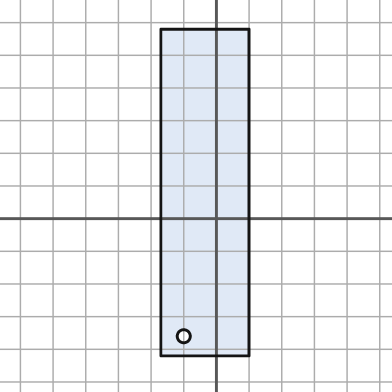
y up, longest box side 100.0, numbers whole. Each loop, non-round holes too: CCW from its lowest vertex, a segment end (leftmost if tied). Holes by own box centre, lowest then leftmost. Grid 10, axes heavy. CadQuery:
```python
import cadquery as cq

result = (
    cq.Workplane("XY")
    .moveTo(-17.0, -42.0)
    .lineTo(10.0, -42.0)
    .lineTo(10.0, 58.0)
    .lineTo(-17.0, 58.0)
    .close()
    .moveTo(-10.0, -36.0)
    .circle(2.0)
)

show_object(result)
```